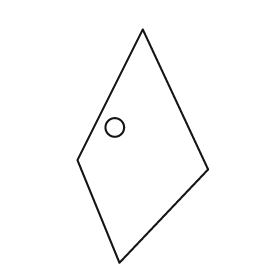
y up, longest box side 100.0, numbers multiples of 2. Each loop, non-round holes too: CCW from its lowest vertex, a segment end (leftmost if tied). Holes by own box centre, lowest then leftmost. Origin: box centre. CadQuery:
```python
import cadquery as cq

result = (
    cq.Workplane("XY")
    .moveTo(-10.0, -50.0)
    .lineTo(28.0, -10.0)
    .lineTo(0.0, 50.0)
    .lineTo(-28.0, -6.0)
    .close()
    .moveTo(-12.0, 8.0)
    .circle(4.0)
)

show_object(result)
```